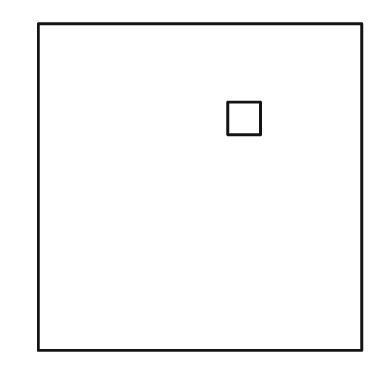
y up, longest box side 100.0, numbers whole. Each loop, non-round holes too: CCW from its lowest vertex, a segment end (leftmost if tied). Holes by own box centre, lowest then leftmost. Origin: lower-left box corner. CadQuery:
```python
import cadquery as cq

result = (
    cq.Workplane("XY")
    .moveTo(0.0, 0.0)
    .lineTo(99.0, 0.0)
    .lineTo(99.0, 100.0)
    .lineTo(0.0, 100.0)
    .close()
    .moveTo(58.0, 66.0)
    .lineTo(68.0, 66.0)
    .lineTo(68.0, 76.0)
    .lineTo(58.0, 76.0)
    .close()
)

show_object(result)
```